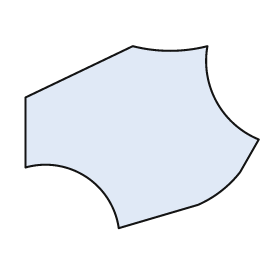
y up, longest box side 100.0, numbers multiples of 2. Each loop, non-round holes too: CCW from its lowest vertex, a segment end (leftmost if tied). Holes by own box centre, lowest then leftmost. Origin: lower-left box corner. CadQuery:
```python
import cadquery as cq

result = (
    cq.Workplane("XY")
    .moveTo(40.0, 0.0)
    .lineTo(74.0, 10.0)
    .threePointArc((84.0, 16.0), (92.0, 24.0))
    .lineTo(100.0, 38.0)
    .threePointArc((82.0, 54.0), (78.0, 78.0))
    .threePointArc((62.0, 76.0), (46.0, 78.0))
    .lineTo(0.0, 56.0)
    .lineTo(0.0, 26.0)
    .threePointArc((26.0, 22.0), (40.0, 0.0))
    .close()
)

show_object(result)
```